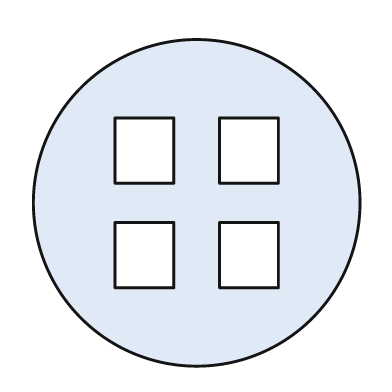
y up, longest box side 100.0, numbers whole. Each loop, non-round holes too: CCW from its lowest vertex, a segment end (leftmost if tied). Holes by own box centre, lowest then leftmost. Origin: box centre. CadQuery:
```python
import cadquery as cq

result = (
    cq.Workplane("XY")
    .moveTo(0.0, 0.0)
    .circle(50.0)
    .moveTo(-25.0, -26.0)
    .lineTo(-7.0, -26.0)
    .lineTo(-7.0, -6.0)
    .lineTo(-25.0, -6.0)
    .close()
    .moveTo(7.0, -26.0)
    .lineTo(25.0, -26.0)
    .lineTo(25.0, -6.0)
    .lineTo(7.0, -6.0)
    .close()
    .moveTo(-25.0, 6.0)
    .lineTo(-7.0, 6.0)
    .lineTo(-7.0, 26.0)
    .lineTo(-25.0, 26.0)
    .close()
    .moveTo(7.0, 6.0)
    .lineTo(25.0, 6.0)
    .lineTo(25.0, 26.0)
    .lineTo(7.0, 26.0)
    .close()
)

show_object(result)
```